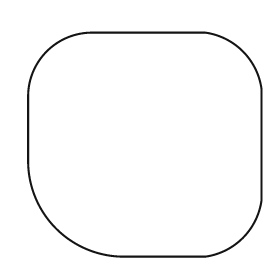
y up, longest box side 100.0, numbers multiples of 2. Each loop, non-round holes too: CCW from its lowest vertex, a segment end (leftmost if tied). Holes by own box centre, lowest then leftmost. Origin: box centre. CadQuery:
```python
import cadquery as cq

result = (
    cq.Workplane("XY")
    .moveTo(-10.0, -48.0)
    .lineTo(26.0, -48.0)
    .threePointArc((42.0, -40.0), (50.0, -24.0))
    .lineTo(50.0, 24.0)
    .threePointArc((42.0, 40.0), (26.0, 48.0))
    .lineTo(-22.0, 48.0)
    .threePointArc((-42.0, 40.0), (-50.0, 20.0))
    .lineTo(-50.0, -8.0)
    .threePointArc((-38.0, -36.0), (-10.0, -48.0))
    .close()
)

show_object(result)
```